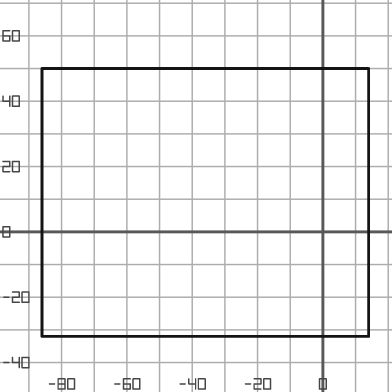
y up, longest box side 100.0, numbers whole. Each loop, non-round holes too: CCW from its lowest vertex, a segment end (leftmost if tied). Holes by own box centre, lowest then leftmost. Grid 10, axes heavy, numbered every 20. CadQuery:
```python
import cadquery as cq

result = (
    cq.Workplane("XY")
    .moveTo(-86.0, -32.0)
    .lineTo(14.0, -32.0)
    .lineTo(14.0, 50.0)
    .lineTo(-86.0, 50.0)
    .close()
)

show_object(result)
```